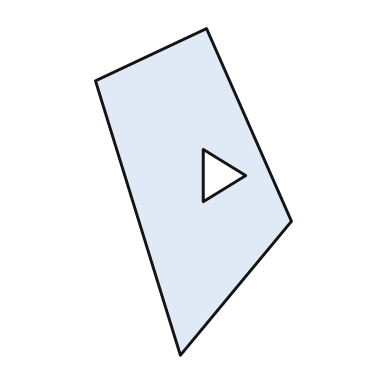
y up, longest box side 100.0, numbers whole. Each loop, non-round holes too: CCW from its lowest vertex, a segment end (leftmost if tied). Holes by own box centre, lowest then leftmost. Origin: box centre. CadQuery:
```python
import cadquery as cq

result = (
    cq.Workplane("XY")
    .moveTo(-4.0, -50.0)
    .lineTo(30.0, -9.0)
    .lineTo(4.0, 50.0)
    .lineTo(-30.0, 34.0)
    .close()
    .moveTo(3.0, -3.0)
    .lineTo(16.0, 5.0)
    .lineTo(3.0, 13.0)
    .close()
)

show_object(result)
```